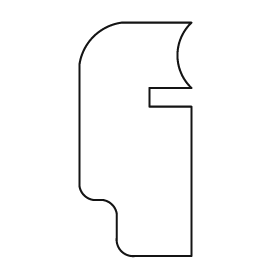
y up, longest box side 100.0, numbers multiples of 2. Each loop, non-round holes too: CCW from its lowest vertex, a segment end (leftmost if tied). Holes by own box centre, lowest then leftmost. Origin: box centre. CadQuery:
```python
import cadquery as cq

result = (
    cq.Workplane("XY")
    .moveTo(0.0, -50.0)
    .lineTo(24.0, -50.0)
    .lineTo(24.0, 14.0)
    .lineTo(6.0, 14.0)
    .lineTo(6.0, 22.0)
    .lineTo(24.0, 22.0)
    .threePointArc((18.0, 36.0), (24.0, 50.0))
    .lineTo(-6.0, 50.0)
    .threePointArc((-18.0, 44.0), (-24.0, 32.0))
    .lineTo(-24.0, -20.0)
    .threePointArc((-22.0, -24.0), (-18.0, -26.0))
    .lineTo(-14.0, -26.0)
    .threePointArc((-10.0, -28.0), (-8.0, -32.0))
    .lineTo(-8.0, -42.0)
    .threePointArc((-6.0, -48.0), (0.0, -50.0))
    .close()
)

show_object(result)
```